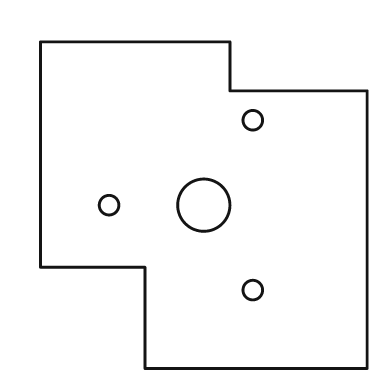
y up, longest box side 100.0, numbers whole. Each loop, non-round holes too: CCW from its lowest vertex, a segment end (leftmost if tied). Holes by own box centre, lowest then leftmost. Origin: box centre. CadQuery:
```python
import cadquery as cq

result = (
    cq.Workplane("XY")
    .moveTo(-18.0, -50.0)
    .lineTo(50.0, -50.0)
    .lineTo(50.0, 35.0)
    .lineTo(8.0, 35.0)
    .lineTo(8.0, 50.0)
    .lineTo(-50.0, 50.0)
    .lineTo(-50.0, -19.0)
    .lineTo(-18.0, -19.0)
    .close()
    .moveTo(15.0, -26.0)
    .circle(3.0)
    .moveTo(-29.0, 0.0)
    .circle(3.0)
    .moveTo(0.0, 0.0)
    .circle(8.0)
    .moveTo(15.0, 26.0)
    .circle(3.0)
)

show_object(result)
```